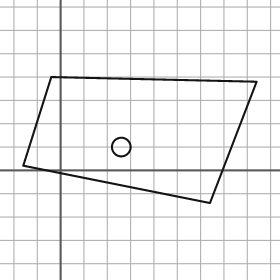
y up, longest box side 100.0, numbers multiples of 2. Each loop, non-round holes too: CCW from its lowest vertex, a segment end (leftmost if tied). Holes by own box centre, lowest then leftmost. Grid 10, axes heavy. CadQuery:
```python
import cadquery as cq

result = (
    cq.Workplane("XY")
    .moveTo(64.0, -14.0)
    .lineTo(84.0, 38.0)
    .lineTo(-4.0, 40.0)
    .lineTo(-16.0, 2.0)
    .close()
    .moveTo(26.0, 10.0)
    .circle(4.0)
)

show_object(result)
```